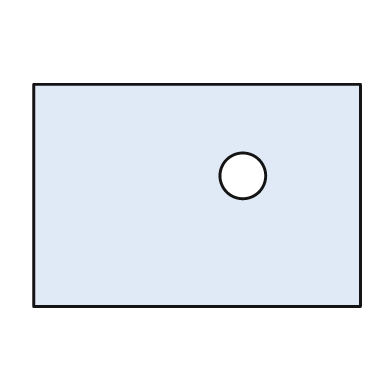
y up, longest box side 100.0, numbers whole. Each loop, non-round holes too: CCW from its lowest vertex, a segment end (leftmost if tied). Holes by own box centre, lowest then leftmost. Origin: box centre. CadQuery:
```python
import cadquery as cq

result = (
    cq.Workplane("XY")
    .moveTo(-50.0, -34.0)
    .lineTo(50.0, -34.0)
    .lineTo(50.0, 34.0)
    .lineTo(-50.0, 34.0)
    .close()
    .moveTo(14.0, 6.0)
    .circle(7.0)
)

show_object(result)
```